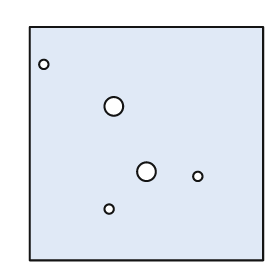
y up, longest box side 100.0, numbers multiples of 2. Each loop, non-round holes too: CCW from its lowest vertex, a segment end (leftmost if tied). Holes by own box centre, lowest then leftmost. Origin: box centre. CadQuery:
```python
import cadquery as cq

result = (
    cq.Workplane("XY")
    .moveTo(-50.0, -50.0)
    .lineTo(50.0, -50.0)
    .lineTo(50.0, 50.0)
    .lineTo(-50.0, 50.0)
    .close()
    .moveTo(-16.0, -28.0)
    .circle(2.0)
    .moveTo(22.0, -14.0)
    .circle(2.0)
    .moveTo(0.0, -12.0)
    .circle(4.0)
    .moveTo(-14.0, 16.0)
    .circle(4.0)
    .moveTo(-44.0, 34.0)
    .circle(2.0)
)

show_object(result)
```